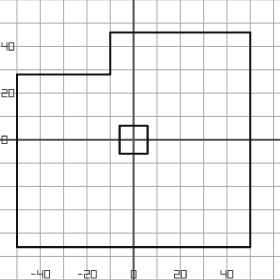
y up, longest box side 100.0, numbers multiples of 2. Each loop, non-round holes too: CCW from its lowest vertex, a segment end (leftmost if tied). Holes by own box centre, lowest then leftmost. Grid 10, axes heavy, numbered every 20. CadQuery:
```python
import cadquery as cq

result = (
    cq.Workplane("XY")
    .moveTo(-50.0, -46.0)
    .lineTo(50.0, -46.0)
    .lineTo(50.0, 46.0)
    .lineTo(-10.0, 46.0)
    .lineTo(-10.0, 28.0)
    .lineTo(-50.0, 28.0)
    .close()
    .moveTo(-6.0, -6.0)
    .lineTo(6.0, -6.0)
    .lineTo(6.0, 6.0)
    .lineTo(-6.0, 6.0)
    .close()
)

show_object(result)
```